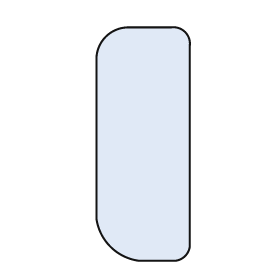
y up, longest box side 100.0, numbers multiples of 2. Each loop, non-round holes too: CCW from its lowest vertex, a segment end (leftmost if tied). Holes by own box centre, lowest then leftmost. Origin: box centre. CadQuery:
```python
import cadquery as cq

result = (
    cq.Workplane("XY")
    .moveTo(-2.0, -50.0)
    .lineTo(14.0, -50.0)
    .threePointArc((18.0, -48.0), (20.0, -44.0))
    .lineTo(20.0, 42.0)
    .threePointArc((18.0, 48.0), (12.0, 50.0))
    .lineTo(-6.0, 50.0)
    .threePointArc((-16.0, 46.0), (-20.0, 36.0))
    .lineTo(-20.0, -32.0)
    .threePointArc((-14.0, -44.0), (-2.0, -50.0))
    .close()
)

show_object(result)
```